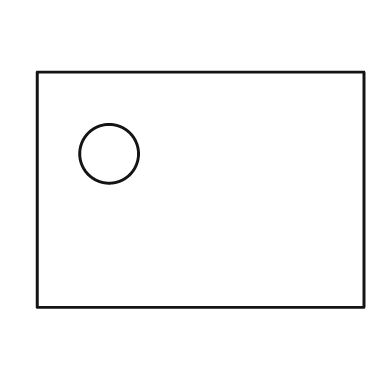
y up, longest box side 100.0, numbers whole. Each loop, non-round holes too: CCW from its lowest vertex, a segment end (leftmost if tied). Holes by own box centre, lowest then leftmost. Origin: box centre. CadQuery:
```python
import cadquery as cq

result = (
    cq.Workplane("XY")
    .moveTo(-50.0, -36.0)
    .lineTo(50.0, -36.0)
    .lineTo(50.0, 36.0)
    .lineTo(-50.0, 36.0)
    .close()
    .moveTo(-28.0, 11.0)
    .circle(9.0)
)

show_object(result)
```